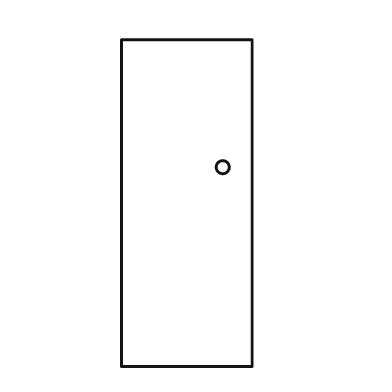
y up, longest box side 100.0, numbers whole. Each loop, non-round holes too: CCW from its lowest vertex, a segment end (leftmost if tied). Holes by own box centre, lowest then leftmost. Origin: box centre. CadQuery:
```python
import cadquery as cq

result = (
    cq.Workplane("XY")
    .moveTo(-20.0, -50.0)
    .lineTo(20.0, -50.0)
    .lineTo(20.0, 50.0)
    .lineTo(-20.0, 50.0)
    .close()
    .moveTo(11.0, 11.0)
    .circle(2.0)
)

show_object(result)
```